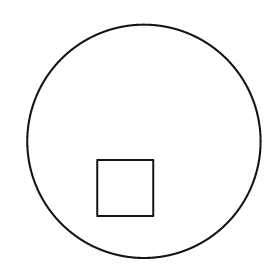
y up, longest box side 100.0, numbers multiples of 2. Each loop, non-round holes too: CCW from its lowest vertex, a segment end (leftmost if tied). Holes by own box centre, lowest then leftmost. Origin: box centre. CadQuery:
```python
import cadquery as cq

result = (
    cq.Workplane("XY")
    .moveTo(0.0, 0.0)
    .circle(50.0)
    .moveTo(-20.0, -32.0)
    .lineTo(4.0, -32.0)
    .lineTo(4.0, -8.0)
    .lineTo(-20.0, -8.0)
    .close()
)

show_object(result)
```